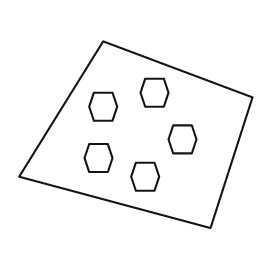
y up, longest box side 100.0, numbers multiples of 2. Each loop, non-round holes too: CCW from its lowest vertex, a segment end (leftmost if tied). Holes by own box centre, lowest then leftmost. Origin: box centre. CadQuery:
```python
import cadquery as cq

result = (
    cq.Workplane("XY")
    .moveTo(32.0, -40.0)
    .lineTo(50.0, 16.0)
    .lineTo(-14.0, 40.0)
    .lineTo(-50.0, -18.0)
    .close()
    .moveTo(0.0, -24.0)
    .lineTo(8.0, -24.0)
    .lineTo(10.0, -18.0)
    .lineTo(8.0, -12.0)
    .lineTo(0.0, -12.0)
    .lineTo(-2.0, -18.0)
    .close()
    .moveTo(-20.0, -16.0)
    .lineTo(-12.0, -16.0)
    .lineTo(-10.0, -10.0)
    .lineTo(-12.0, -4.0)
    .lineTo(-20.0, -4.0)
    .lineTo(-22.0, -10.0)
    .close()
    .moveTo(16.0, -8.0)
    .lineTo(24.0, -8.0)
    .lineTo(26.0, -2.0)
    .lineTo(24.0, 4.0)
    .lineTo(16.0, 4.0)
    .lineTo(14.0, -2.0)
    .close()
    .moveTo(-18.0, 6.0)
    .lineTo(-10.0, 6.0)
    .lineTo(-8.0, 12.0)
    .lineTo(-10.0, 18.0)
    .lineTo(-18.0, 18.0)
    .lineTo(-20.0, 12.0)
    .close()
    .moveTo(4.0, 12.0)
    .lineTo(12.0, 12.0)
    .lineTo(14.0, 18.0)
    .lineTo(12.0, 24.0)
    .lineTo(4.0, 24.0)
    .lineTo(2.0, 18.0)
    .close()
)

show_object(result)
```